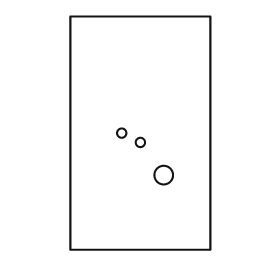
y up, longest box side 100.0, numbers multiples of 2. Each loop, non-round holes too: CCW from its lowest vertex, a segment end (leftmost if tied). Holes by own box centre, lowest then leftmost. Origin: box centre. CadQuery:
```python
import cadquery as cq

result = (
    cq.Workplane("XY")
    .moveTo(-30.0, -50.0)
    .lineTo(30.0, -50.0)
    .lineTo(30.0, 50.0)
    .lineTo(-30.0, 50.0)
    .close()
    .moveTo(10.0, -18.0)
    .circle(4.0)
    .moveTo(0.0, -4.0)
    .circle(2.0)
    .moveTo(-8.0, 0.0)
    .circle(2.0)
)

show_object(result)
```